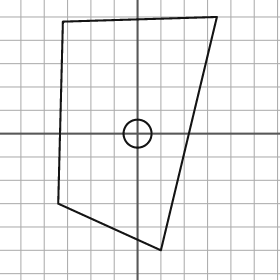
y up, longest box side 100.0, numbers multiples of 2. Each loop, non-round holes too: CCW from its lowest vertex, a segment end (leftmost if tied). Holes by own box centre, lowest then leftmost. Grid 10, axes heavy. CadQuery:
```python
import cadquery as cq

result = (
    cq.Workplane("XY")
    .moveTo(10.0, -50.0)
    .lineTo(34.0, 50.0)
    .lineTo(-32.0, 48.0)
    .lineTo(-34.0, -30.0)
    .close()
    .moveTo(0.0, 0.0)
    .circle(6.0)
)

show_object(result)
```